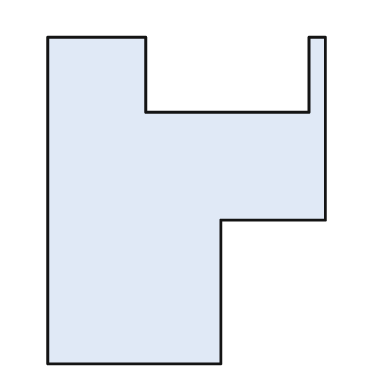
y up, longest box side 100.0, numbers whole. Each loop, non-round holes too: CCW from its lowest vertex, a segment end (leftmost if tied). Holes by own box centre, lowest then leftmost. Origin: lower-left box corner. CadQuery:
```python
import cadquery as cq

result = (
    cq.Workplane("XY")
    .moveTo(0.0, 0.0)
    .lineTo(53.0, 0.0)
    .lineTo(53.0, 44.0)
    .lineTo(85.0, 44.0)
    .lineTo(85.0, 100.0)
    .lineTo(80.0, 100.0)
    .lineTo(80.0, 77.0)
    .lineTo(30.0, 77.0)
    .lineTo(30.0, 100.0)
    .lineTo(0.0, 100.0)
    .close()
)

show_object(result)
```